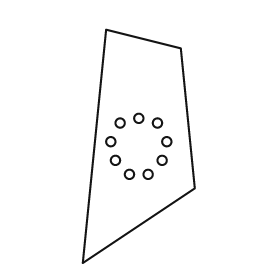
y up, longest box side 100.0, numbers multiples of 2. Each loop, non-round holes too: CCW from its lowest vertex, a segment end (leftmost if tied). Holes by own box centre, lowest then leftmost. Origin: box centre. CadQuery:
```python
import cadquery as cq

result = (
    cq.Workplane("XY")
    .moveTo(-24.0, -50.0)
    .lineTo(24.0, -18.0)
    .lineTo(18.0, 42.0)
    .lineTo(-14.0, 50.0)
    .close()
    .moveTo(-4.0, -12.0)
    .circle(2.0)
    .moveTo(4.0, -12.0)
    .circle(2.0)
    .moveTo(-10.0, -6.0)
    .circle(2.0)
    .moveTo(10.0, -6.0)
    .circle(2.0)
    .moveTo(-12.0, 2.0)
    .circle(2.0)
    .moveTo(12.0, 2.0)
    .circle(2.0)
    .moveTo(-8.0, 10.0)
    .circle(2.0)
    .moveTo(8.0, 10.0)
    .circle(2.0)
    .moveTo(0.0, 12.0)
    .circle(2.0)
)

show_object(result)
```